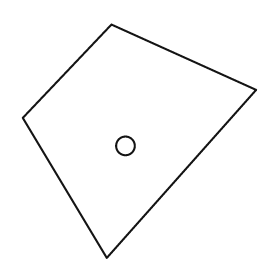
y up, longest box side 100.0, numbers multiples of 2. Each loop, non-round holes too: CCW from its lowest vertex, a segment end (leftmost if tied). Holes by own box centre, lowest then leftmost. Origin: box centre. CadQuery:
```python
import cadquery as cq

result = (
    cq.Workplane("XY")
    .moveTo(-14.0, -50.0)
    .lineTo(50.0, 22.0)
    .lineTo(-12.0, 50.0)
    .lineTo(-50.0, 10.0)
    .close()
    .moveTo(-6.0, -2.0)
    .circle(4.0)
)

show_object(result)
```